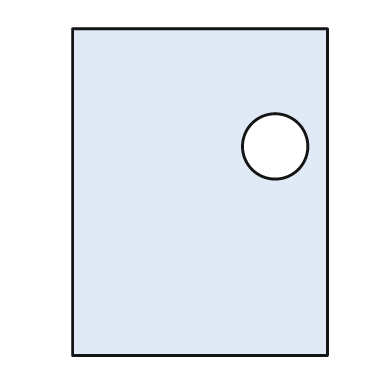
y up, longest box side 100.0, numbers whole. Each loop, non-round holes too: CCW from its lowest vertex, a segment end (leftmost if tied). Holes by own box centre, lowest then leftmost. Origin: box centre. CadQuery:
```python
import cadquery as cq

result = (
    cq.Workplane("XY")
    .moveTo(-39.0, -50.0)
    .lineTo(39.0, -50.0)
    .lineTo(39.0, 50.0)
    .lineTo(-39.0, 50.0)
    .close()
    .moveTo(23.0, 14.0)
    .circle(10.0)
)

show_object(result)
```